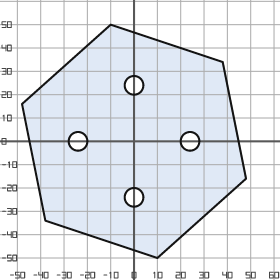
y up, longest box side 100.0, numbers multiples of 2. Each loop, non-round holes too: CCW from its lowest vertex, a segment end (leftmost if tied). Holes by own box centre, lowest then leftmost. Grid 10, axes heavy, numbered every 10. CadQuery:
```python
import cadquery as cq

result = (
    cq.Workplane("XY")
    .moveTo(10.0, -50.0)
    .lineTo(48.0, -16.0)
    .lineTo(38.0, 34.0)
    .lineTo(-10.0, 50.0)
    .lineTo(-48.0, 16.0)
    .lineTo(-38.0, -34.0)
    .close()
    .moveTo(0.0, -24.0)
    .circle(4.0)
    .moveTo(-24.0, 0.0)
    .circle(4.0)
    .moveTo(24.0, 0.0)
    .circle(4.0)
    .moveTo(0.0, 24.0)
    .circle(4.0)
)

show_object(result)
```